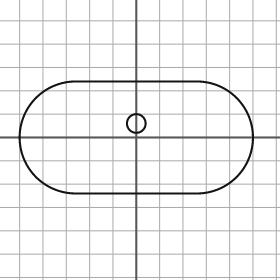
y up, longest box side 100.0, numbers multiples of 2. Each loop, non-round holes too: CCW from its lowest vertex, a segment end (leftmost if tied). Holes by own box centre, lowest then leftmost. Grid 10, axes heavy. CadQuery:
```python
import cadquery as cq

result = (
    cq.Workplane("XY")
    .moveTo(-26.0, -24.0)
    .lineTo(26.0, -24.0)
    .threePointArc((50.0, 0.0), (26.0, 24.0))
    .lineTo(-26.0, 24.0)
    .threePointArc((-50.0, 0.0), (-26.0, -24.0))
    .close()
    .moveTo(0.0, 6.0)
    .circle(4.0)
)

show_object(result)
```